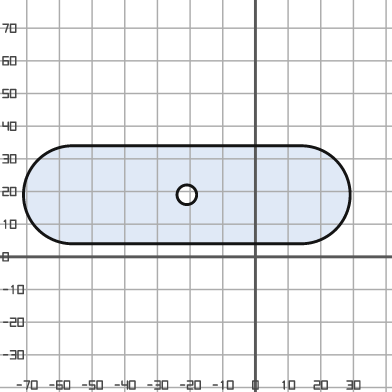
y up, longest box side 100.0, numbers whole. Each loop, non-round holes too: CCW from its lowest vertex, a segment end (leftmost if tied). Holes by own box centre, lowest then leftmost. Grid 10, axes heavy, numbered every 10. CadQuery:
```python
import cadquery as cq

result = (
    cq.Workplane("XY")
    .moveTo(-56.0, 4.0)
    .lineTo(14.0, 4.0)
    .threePointArc((29.0, 19.0), (14.0, 34.0))
    .lineTo(-56.0, 34.0)
    .threePointArc((-71.0, 19.0), (-56.0, 4.0))
    .close()
    .moveTo(-21.0, 19.0)
    .circle(3.0)
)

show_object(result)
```